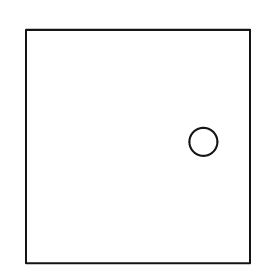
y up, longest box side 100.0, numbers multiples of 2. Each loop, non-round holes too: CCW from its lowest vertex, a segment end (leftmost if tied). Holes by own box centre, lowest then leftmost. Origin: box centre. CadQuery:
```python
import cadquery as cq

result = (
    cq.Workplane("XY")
    .moveTo(-48.0, -50.0)
    .lineTo(48.0, -50.0)
    .lineTo(48.0, 50.0)
    .lineTo(-48.0, 50.0)
    .close()
    .moveTo(28.0, 2.0)
    .circle(6.0)
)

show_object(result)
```